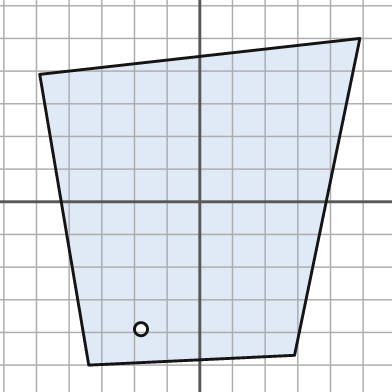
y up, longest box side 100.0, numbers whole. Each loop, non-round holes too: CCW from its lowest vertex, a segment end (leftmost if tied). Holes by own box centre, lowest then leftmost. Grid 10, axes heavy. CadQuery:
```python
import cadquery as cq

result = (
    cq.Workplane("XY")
    .moveTo(-34.0, -50.0)
    .lineTo(29.0, -47.0)
    .lineTo(49.0, 50.0)
    .lineTo(-49.0, 39.0)
    .close()
    .moveTo(-18.0, -39.0)
    .circle(2.0)
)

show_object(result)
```